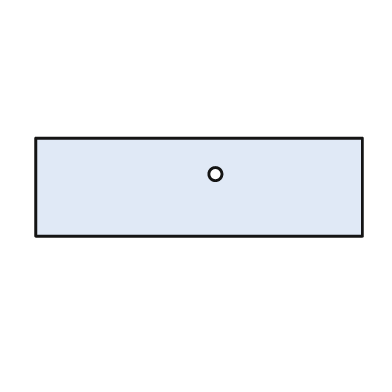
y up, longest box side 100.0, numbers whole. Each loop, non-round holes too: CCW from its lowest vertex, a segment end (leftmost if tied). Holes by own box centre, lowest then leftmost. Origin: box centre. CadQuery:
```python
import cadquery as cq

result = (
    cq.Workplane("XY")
    .moveTo(-50.0, -15.0)
    .lineTo(50.0, -15.0)
    .lineTo(50.0, 15.0)
    .lineTo(-50.0, 15.0)
    .close()
    .moveTo(5.0, 4.0)
    .circle(2.0)
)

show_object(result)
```